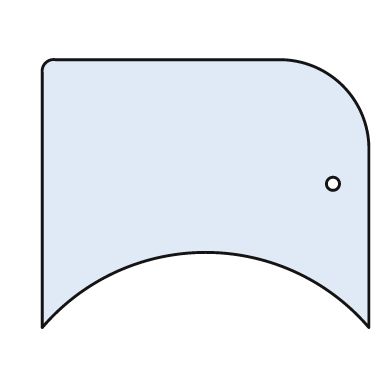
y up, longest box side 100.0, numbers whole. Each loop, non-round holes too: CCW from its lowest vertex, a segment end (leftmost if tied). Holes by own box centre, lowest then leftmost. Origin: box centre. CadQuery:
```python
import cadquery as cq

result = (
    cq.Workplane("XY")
    .moveTo(-50.0, -41.0)
    .threePointArc((0.0, -18.0), (50.0, -41.0))
    .lineTo(50.0, 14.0)
    .threePointArc((42.0, 33.0), (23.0, 41.0))
    .lineTo(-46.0, 41.0)
    .threePointArc((-49.0, 40.0), (-50.0, 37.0))
    .close()
    .moveTo(39.0, 3.0)
    .circle(2.0)
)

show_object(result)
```